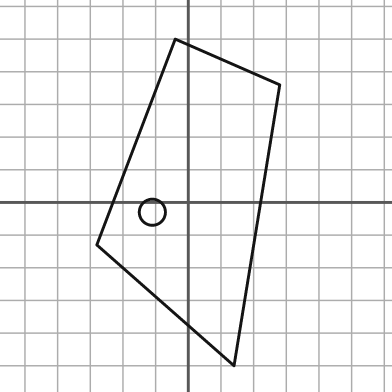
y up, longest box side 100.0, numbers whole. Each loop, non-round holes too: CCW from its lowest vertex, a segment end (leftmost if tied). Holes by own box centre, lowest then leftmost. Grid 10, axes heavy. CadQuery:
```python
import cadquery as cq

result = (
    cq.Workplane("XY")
    .moveTo(14.0, -50.0)
    .lineTo(28.0, 36.0)
    .lineTo(-4.0, 50.0)
    .lineTo(-28.0, -13.0)
    .close()
    .moveTo(-11.0, -3.0)
    .circle(4.0)
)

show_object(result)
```